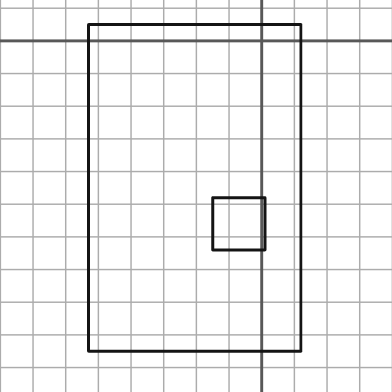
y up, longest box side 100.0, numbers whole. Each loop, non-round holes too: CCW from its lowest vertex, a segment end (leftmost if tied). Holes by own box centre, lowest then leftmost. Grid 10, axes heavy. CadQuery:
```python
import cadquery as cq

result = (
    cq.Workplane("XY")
    .moveTo(-53.0, -95.0)
    .lineTo(12.0, -95.0)
    .lineTo(12.0, 5.0)
    .lineTo(-53.0, 5.0)
    .close()
    .moveTo(-15.0, -64.0)
    .lineTo(1.0, -64.0)
    .lineTo(1.0, -48.0)
    .lineTo(-15.0, -48.0)
    .close()
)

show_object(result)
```